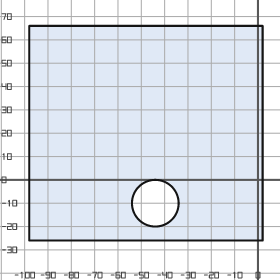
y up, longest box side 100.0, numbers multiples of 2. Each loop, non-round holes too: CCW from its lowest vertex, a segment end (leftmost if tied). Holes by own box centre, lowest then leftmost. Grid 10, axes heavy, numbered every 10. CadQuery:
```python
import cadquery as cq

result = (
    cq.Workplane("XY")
    .moveTo(-98.0, -26.0)
    .lineTo(2.0, -26.0)
    .lineTo(2.0, 66.0)
    .lineTo(-98.0, 66.0)
    .close()
    .moveTo(-44.0, -10.0)
    .circle(10.0)
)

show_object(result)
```